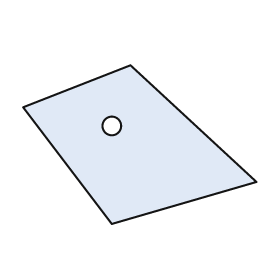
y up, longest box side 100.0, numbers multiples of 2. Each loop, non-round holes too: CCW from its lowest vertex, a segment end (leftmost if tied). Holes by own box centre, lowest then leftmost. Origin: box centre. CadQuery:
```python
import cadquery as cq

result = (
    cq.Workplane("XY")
    .moveTo(-12.0, -34.0)
    .lineTo(50.0, -16.0)
    .lineTo(-4.0, 34.0)
    .lineTo(-50.0, 16.0)
    .close()
    .moveTo(-12.0, 8.0)
    .circle(4.0)
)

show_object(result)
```